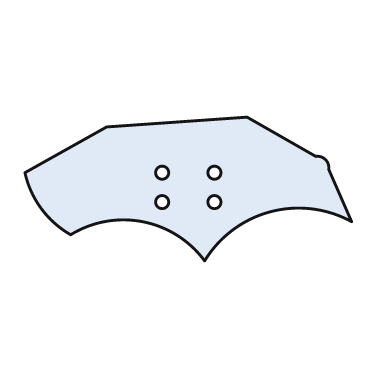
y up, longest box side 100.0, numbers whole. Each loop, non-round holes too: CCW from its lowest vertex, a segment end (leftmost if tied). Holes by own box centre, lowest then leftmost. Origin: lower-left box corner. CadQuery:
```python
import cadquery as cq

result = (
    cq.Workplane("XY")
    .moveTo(55.0, 0.0)
    .threePointArc((75.0, 15.0), (100.0, 12.0))
    .lineTo(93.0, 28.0)
    .threePointArc((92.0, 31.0), (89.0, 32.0))
    .lineTo(68.0, 44.0)
    .lineTo(25.0, 41.0)
    .lineTo(0.0, 27.0)
    .threePointArc((5.0, 16.0), (14.0, 8.0))
    .threePointArc((36.0, 12.0), (55.0, 0.0))
    .close()
    .moveTo(42.0, 18.0)
    .circle(2.0)
    .moveTo(58.0, 18.0)
    .circle(2.0)
    .moveTo(42.0, 27.0)
    .circle(2.0)
    .moveTo(58.0, 27.0)
    .circle(2.0)
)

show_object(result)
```